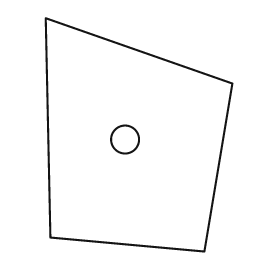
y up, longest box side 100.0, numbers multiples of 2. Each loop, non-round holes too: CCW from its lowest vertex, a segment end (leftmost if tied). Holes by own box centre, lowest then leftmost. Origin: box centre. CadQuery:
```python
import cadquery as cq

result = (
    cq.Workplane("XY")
    .moveTo(28.0, -50.0)
    .lineTo(40.0, 22.0)
    .lineTo(-40.0, 50.0)
    .lineTo(-38.0, -44.0)
    .close()
    .moveTo(-6.0, -2.0)
    .circle(6.0)
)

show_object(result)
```